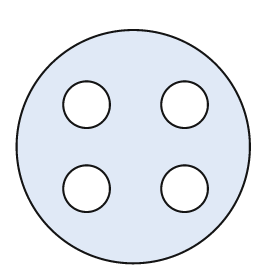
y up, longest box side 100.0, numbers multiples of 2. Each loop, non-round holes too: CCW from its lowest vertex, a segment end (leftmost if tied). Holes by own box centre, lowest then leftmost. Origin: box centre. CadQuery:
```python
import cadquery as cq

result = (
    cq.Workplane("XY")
    .moveTo(0.0, 0.0)
    .circle(50.0)
    .moveTo(-20.0, -18.0)
    .circle(10.0)
    .moveTo(22.0, -18.0)
    .circle(10.0)
    .moveTo(-20.0, 18.0)
    .circle(10.0)
    .moveTo(22.0, 18.0)
    .circle(10.0)
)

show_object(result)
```